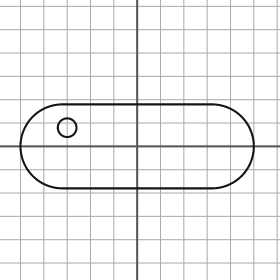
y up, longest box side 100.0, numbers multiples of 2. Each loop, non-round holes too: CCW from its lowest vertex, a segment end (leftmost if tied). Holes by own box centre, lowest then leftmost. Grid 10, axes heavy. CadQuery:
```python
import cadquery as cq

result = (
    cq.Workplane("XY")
    .moveTo(-32.0, -18.0)
    .lineTo(32.0, -18.0)
    .threePointArc((50.0, 0.0), (32.0, 18.0))
    .lineTo(-32.0, 18.0)
    .threePointArc((-50.0, 0.0), (-32.0, -18.0))
    .close()
    .moveTo(-30.0, 8.0)
    .circle(4.0)
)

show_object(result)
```